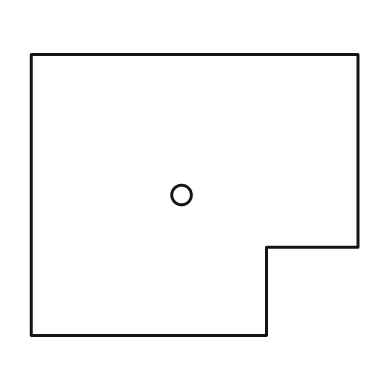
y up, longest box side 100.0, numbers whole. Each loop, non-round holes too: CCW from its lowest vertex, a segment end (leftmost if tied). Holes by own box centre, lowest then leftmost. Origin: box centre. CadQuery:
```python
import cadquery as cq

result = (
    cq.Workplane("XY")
    .moveTo(-50.0, -43.0)
    .lineTo(22.0, -43.0)
    .lineTo(22.0, -16.0)
    .lineTo(50.0, -16.0)
    .lineTo(50.0, 43.0)
    .lineTo(-50.0, 43.0)
    .close()
    .moveTo(-4.0, 0.0)
    .circle(3.0)
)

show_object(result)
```